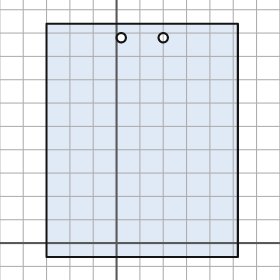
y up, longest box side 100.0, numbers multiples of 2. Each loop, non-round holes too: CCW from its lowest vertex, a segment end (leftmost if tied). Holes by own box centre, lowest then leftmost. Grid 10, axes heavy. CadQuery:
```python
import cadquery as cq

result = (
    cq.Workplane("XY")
    .moveTo(-30.0, -6.0)
    .lineTo(52.0, -6.0)
    .lineTo(52.0, 94.0)
    .lineTo(-30.0, 94.0)
    .close()
    .moveTo(2.0, 88.0)
    .circle(2.0)
    .moveTo(20.0, 88.0)
    .circle(2.0)
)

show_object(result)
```